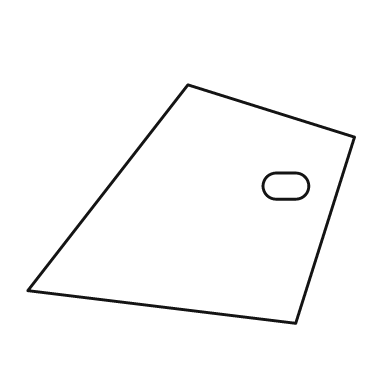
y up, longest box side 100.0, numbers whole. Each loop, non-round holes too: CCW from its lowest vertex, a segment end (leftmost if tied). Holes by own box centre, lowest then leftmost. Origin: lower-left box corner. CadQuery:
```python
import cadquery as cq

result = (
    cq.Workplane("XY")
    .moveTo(82.0, 0.0)
    .lineTo(100.0, 57.0)
    .lineTo(49.0, 73.0)
    .lineTo(0.0, 10.0)
    .close()
    .moveTo(76.0, 38.0)
    .lineTo(82.0, 38.0)
    .threePointArc((86.0, 42.0), (82.0, 46.0))
    .lineTo(76.0, 46.0)
    .threePointArc((72.0, 42.0), (76.0, 38.0))
    .close()
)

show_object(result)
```